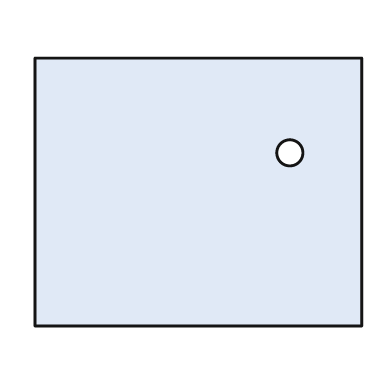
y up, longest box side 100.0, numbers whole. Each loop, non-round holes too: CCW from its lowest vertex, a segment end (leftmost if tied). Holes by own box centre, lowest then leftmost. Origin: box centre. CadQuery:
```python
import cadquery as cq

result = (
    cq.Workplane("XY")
    .moveTo(-50.0, -41.0)
    .lineTo(50.0, -41.0)
    .lineTo(50.0, 41.0)
    .lineTo(-50.0, 41.0)
    .close()
    .moveTo(28.0, 12.0)
    .circle(4.0)
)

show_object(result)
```